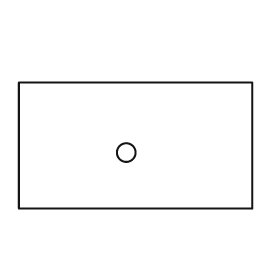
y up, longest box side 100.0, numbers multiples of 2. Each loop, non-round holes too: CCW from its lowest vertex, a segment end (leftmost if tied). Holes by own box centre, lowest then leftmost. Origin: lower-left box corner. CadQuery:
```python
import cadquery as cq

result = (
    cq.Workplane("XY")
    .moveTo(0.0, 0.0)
    .lineTo(100.0, 0.0)
    .lineTo(100.0, 54.0)
    .lineTo(0.0, 54.0)
    .close()
    .moveTo(46.0, 24.0)
    .circle(4.0)
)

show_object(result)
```